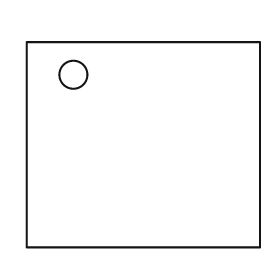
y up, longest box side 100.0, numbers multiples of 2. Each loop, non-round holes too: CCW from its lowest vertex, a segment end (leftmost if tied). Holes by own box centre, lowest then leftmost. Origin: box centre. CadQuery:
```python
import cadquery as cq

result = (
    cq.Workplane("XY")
    .moveTo(-50.0, -44.0)
    .lineTo(50.0, -44.0)
    .lineTo(50.0, 44.0)
    .lineTo(-50.0, 44.0)
    .close()
    .moveTo(-30.0, 30.0)
    .circle(6.0)
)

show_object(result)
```